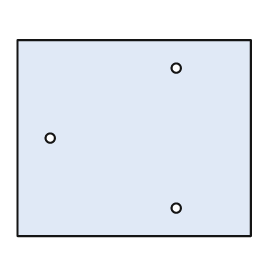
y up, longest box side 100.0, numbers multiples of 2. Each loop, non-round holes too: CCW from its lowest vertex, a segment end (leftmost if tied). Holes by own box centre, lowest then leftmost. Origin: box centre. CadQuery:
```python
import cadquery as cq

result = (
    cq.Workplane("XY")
    .moveTo(-50.0, -42.0)
    .lineTo(50.0, -42.0)
    .lineTo(50.0, 42.0)
    .lineTo(-50.0, 42.0)
    .close()
    .moveTo(18.0, -30.0)
    .circle(2.0)
    .moveTo(-36.0, 0.0)
    .circle(2.0)
    .moveTo(18.0, 30.0)
    .circle(2.0)
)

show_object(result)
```